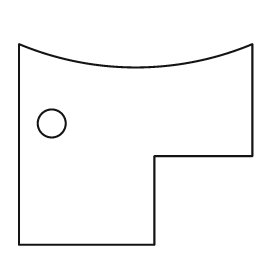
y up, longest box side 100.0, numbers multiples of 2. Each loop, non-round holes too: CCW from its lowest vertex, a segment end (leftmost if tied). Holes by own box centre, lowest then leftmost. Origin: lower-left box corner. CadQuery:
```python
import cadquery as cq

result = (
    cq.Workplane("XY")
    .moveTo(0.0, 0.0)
    .lineTo(58.0, 0.0)
    .lineTo(58.0, 38.0)
    .lineTo(100.0, 38.0)
    .lineTo(100.0, 86.0)
    .threePointArc((50.0, 76.0), (0.0, 86.0))
    .close()
    .moveTo(14.0, 52.0)
    .circle(6.0)
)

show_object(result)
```